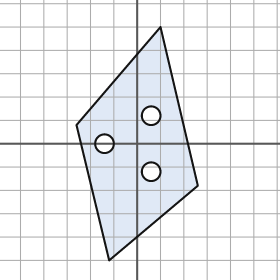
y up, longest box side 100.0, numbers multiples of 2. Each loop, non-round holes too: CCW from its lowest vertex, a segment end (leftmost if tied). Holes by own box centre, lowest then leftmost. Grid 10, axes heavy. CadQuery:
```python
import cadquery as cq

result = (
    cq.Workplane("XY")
    .moveTo(-12.0, -50.0)
    .lineTo(26.0, -18.0)
    .lineTo(10.0, 50.0)
    .lineTo(-26.0, 8.0)
    .close()
    .moveTo(6.0, -12.0)
    .circle(4.0)
    .moveTo(-14.0, 0.0)
    .circle(4.0)
    .moveTo(6.0, 12.0)
    .circle(4.0)
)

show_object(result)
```